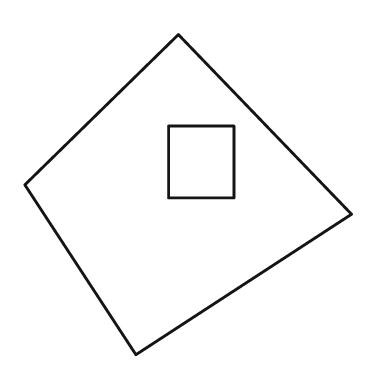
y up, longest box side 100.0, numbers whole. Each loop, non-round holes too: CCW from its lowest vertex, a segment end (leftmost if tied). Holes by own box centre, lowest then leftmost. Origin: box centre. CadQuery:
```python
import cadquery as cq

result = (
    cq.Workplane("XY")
    .moveTo(-16.0, -49.0)
    .lineTo(50.0, -6.0)
    .lineTo(-3.0, 49.0)
    .lineTo(-50.0, 3.0)
    .close()
    .moveTo(-6.0, -1.0)
    .lineTo(14.0, -1.0)
    .lineTo(14.0, 21.0)
    .lineTo(-6.0, 21.0)
    .close()
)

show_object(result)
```